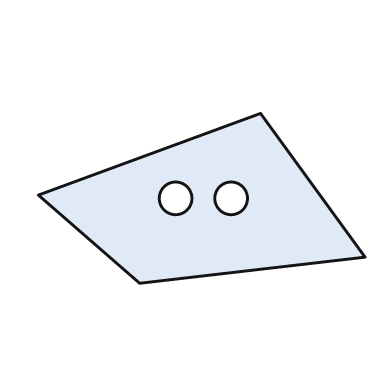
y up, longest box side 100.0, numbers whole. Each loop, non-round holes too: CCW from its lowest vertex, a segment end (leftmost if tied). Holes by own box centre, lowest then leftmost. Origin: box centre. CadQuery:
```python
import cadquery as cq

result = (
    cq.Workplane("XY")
    .moveTo(-19.0, -26.0)
    .lineTo(50.0, -18.0)
    .lineTo(18.0, 26.0)
    .lineTo(-50.0, 1.0)
    .close()
    .moveTo(-8.0, 0.0)
    .circle(5.0)
    .moveTo(9.0, 0.0)
    .circle(5.0)
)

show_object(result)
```